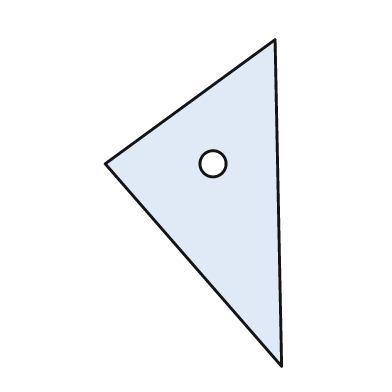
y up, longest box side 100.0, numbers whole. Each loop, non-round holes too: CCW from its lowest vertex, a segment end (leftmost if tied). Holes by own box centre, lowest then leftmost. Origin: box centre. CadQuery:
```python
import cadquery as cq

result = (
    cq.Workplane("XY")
    .moveTo(27.0, -50.0)
    .lineTo(25.0, 50.0)
    .lineTo(-27.0, 12.0)
    .close()
    .moveTo(6.0, 12.0)
    .circle(4.0)
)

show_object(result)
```